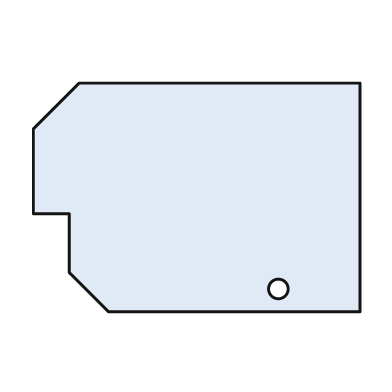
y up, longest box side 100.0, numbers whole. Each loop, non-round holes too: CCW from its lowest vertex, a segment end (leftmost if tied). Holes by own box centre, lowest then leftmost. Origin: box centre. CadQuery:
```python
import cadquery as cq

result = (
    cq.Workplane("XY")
    .moveTo(-27.0, -35.0)
    .lineTo(50.0, -35.0)
    .lineTo(50.0, 35.0)
    .lineTo(-36.0, 35.0)
    .lineTo(-50.0, 21.0)
    .lineTo(-50.0, -5.0)
    .lineTo(-39.0, -5.0)
    .lineTo(-39.0, -23.0)
    .close()
    .moveTo(25.0, -28.0)
    .circle(3.0)
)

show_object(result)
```